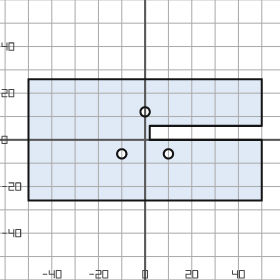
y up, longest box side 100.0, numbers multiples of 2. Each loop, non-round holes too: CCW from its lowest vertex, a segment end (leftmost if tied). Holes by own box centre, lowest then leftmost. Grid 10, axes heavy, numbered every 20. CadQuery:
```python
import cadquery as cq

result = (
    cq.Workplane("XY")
    .moveTo(-50.0, -26.0)
    .lineTo(50.0, -26.0)
    .lineTo(50.0, 0.0)
    .lineTo(2.0, 0.0)
    .lineTo(2.0, 6.0)
    .lineTo(50.0, 6.0)
    .lineTo(50.0, 26.0)
    .lineTo(-50.0, 26.0)
    .close()
    .moveTo(-10.0, -6.0)
    .circle(2.0)
    .moveTo(10.0, -6.0)
    .circle(2.0)
    .moveTo(0.0, 12.0)
    .circle(2.0)
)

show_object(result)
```